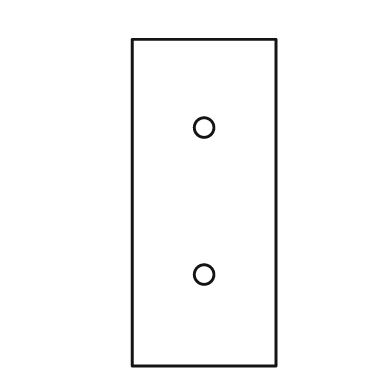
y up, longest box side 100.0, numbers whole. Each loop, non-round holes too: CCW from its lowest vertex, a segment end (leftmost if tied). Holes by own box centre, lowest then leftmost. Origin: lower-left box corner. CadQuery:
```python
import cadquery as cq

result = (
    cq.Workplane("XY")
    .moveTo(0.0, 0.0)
    .lineTo(44.0, 0.0)
    .lineTo(44.0, 100.0)
    .lineTo(0.0, 100.0)
    .close()
    .moveTo(22.0, 28.0)
    .circle(3.0)
    .moveTo(22.0, 73.0)
    .circle(3.0)
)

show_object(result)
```